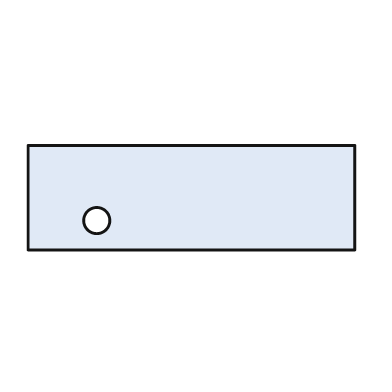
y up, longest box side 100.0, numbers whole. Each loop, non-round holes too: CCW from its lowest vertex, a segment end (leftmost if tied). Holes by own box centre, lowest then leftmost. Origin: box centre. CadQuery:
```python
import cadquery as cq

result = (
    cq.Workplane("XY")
    .moveTo(-50.0, -16.0)
    .lineTo(50.0, -16.0)
    .lineTo(50.0, 16.0)
    .lineTo(-50.0, 16.0)
    .close()
    .moveTo(-29.0, -7.0)
    .circle(4.0)
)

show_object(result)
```